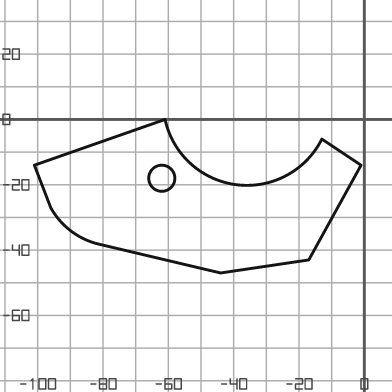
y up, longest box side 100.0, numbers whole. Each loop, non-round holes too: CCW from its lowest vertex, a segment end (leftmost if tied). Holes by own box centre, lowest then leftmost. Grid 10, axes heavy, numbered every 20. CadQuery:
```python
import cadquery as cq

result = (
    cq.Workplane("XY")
    .moveTo(-44.0, -47.0)
    .lineTo(-17.0, -43.0)
    .lineTo(-1.0, -14.0)
    .lineTo(-13.0, -6.0)
    .threePointArc((-39.0, -20.0), (-61.0, 0.0))
    .lineTo(-101.0, -14.0)
    .lineTo(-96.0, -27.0)
    .threePointArc((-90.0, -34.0), (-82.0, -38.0))
    .close()
    .moveTo(-62.0, -18.0)
    .circle(4.0)
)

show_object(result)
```